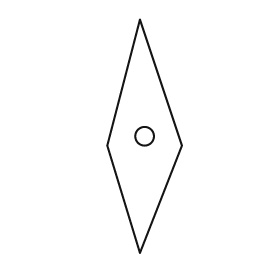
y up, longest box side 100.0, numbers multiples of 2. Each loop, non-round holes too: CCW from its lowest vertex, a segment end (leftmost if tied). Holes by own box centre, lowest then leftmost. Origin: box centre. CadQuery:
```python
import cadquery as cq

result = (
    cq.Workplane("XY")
    .moveTo(-2.0, -50.0)
    .lineTo(16.0, -4.0)
    .lineTo(-2.0, 50.0)
    .lineTo(-16.0, -4.0)
    .close()
    .moveTo(0.0, 0.0)
    .circle(4.0)
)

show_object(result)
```